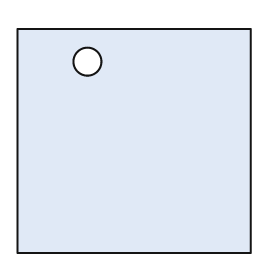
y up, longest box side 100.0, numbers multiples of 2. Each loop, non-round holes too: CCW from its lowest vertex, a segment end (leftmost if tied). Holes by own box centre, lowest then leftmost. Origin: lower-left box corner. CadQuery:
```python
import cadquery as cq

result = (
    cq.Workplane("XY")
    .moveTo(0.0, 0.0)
    .lineTo(100.0, 0.0)
    .lineTo(100.0, 96.0)
    .lineTo(0.0, 96.0)
    .close()
    .moveTo(30.0, 82.0)
    .circle(6.0)
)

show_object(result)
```